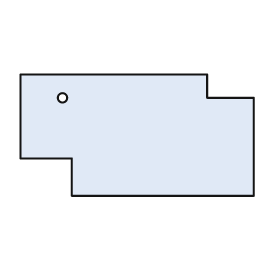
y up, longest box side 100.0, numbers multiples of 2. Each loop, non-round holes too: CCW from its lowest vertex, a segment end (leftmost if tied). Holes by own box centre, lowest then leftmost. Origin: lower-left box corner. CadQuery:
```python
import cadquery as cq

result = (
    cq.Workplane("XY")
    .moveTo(22.0, 0.0)
    .lineTo(100.0, 0.0)
    .lineTo(100.0, 42.0)
    .lineTo(80.0, 42.0)
    .lineTo(80.0, 52.0)
    .lineTo(0.0, 52.0)
    .lineTo(0.0, 16.0)
    .lineTo(22.0, 16.0)
    .close()
    .moveTo(18.0, 42.0)
    .circle(2.0)
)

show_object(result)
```